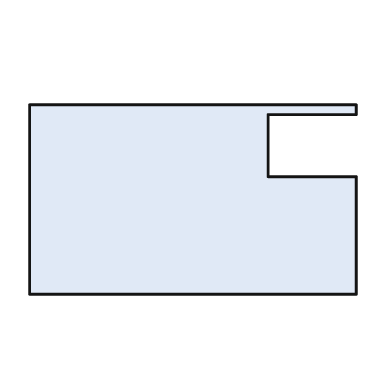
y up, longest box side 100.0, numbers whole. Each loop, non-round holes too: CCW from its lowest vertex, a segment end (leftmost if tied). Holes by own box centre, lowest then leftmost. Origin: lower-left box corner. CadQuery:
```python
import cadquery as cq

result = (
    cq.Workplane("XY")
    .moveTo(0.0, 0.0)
    .lineTo(100.0, 0.0)
    .lineTo(100.0, 36.0)
    .lineTo(73.0, 36.0)
    .lineTo(73.0, 55.0)
    .lineTo(100.0, 55.0)
    .lineTo(100.0, 58.0)
    .lineTo(0.0, 58.0)
    .close()
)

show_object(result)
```